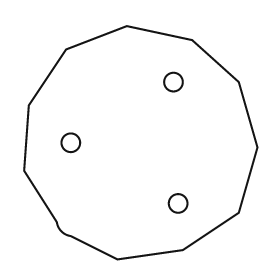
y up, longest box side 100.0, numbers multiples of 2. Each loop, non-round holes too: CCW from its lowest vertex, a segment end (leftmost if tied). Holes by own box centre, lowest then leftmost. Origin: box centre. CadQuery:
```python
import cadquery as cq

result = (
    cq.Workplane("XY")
    .moveTo(-10.0, -50.0)
    .lineTo(18.0, -46.0)
    .lineTo(42.0, -30.0)
    .lineTo(50.0, -2.0)
    .lineTo(42.0, 26.0)
    .lineTo(22.0, 44.0)
    .lineTo(-6.0, 50.0)
    .lineTo(-32.0, 40.0)
    .lineTo(-48.0, 16.0)
    .lineTo(-50.0, -12.0)
    .lineTo(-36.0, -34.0)
    .threePointArc((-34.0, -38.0), (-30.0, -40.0))
    .close()
    .moveTo(16.0, -26.0)
    .circle(4.0)
    .moveTo(-30.0, 0.0)
    .circle(4.0)
    .moveTo(14.0, 26.0)
    .circle(4.0)
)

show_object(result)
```